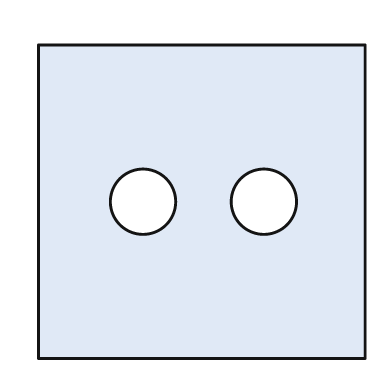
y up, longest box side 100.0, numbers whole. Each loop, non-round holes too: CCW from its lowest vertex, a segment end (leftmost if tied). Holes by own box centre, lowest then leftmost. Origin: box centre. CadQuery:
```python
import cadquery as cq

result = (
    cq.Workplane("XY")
    .moveTo(-50.0, -48.0)
    .lineTo(50.0, -48.0)
    .lineTo(50.0, 48.0)
    .lineTo(-50.0, 48.0)
    .close()
    .moveTo(-18.0, 0.0)
    .circle(10.0)
    .moveTo(19.0, 0.0)
    .circle(10.0)
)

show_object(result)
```